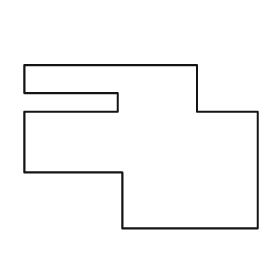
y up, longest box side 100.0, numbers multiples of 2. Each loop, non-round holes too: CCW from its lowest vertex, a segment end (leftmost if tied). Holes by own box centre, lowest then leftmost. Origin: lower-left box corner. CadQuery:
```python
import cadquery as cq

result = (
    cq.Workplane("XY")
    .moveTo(42.0, 0.0)
    .lineTo(100.0, 0.0)
    .lineTo(100.0, 50.0)
    .lineTo(74.0, 50.0)
    .lineTo(74.0, 70.0)
    .lineTo(0.0, 70.0)
    .lineTo(0.0, 58.0)
    .lineTo(40.0, 58.0)
    .lineTo(40.0, 50.0)
    .lineTo(0.0, 50.0)
    .lineTo(0.0, 24.0)
    .lineTo(42.0, 24.0)
    .close()
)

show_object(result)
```